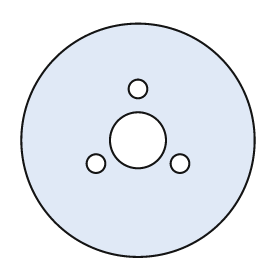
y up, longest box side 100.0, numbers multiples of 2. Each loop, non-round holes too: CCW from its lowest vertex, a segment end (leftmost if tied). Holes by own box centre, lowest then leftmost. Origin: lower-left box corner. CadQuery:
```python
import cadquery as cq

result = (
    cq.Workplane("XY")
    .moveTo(50.0, 50.0)
    .circle(50.0)
    .moveTo(32.0, 40.0)
    .circle(4.0)
    .moveTo(68.0, 40.0)
    .circle(4.0)
    .moveTo(50.0, 50.0)
    .circle(12.0)
    .moveTo(50.0, 72.0)
    .circle(4.0)
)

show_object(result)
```